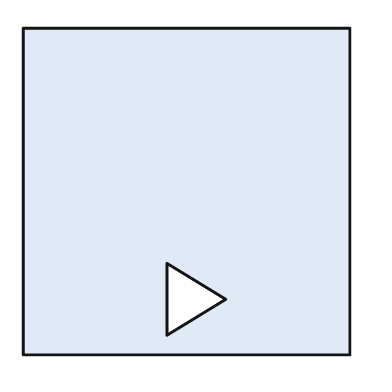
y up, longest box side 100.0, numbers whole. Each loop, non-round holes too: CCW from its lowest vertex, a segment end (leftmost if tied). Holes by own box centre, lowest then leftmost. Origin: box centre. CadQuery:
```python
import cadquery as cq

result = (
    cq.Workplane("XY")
    .moveTo(-50.0, -50.0)
    .lineTo(50.0, -50.0)
    .lineTo(50.0, 50.0)
    .lineTo(-50.0, 50.0)
    .close()
    .moveTo(-6.0, -44.0)
    .lineTo(12.0, -33.0)
    .lineTo(-6.0, -22.0)
    .close()
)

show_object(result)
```